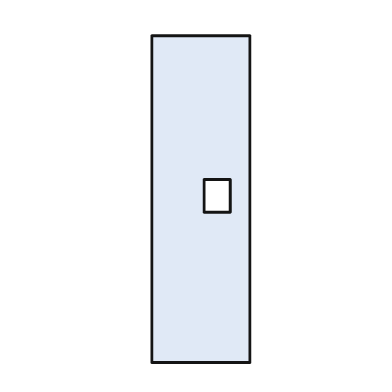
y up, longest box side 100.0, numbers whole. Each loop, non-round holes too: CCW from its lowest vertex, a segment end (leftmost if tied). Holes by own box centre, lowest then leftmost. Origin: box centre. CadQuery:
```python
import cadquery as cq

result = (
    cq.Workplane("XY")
    .moveTo(-15.0, -50.0)
    .lineTo(15.0, -50.0)
    .lineTo(15.0, 50.0)
    .lineTo(-15.0, 50.0)
    .close()
    .moveTo(1.0, -4.0)
    .lineTo(9.0, -4.0)
    .lineTo(9.0, 6.0)
    .lineTo(1.0, 6.0)
    .close()
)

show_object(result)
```